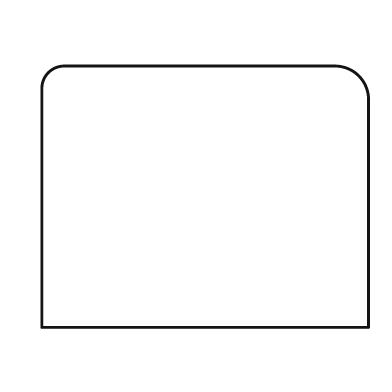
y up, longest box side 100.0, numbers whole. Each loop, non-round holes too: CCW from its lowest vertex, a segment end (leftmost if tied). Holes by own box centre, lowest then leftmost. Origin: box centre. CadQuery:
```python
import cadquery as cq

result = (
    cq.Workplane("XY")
    .moveTo(-50.0, -40.0)
    .lineTo(50.0, -40.0)
    .lineTo(50.0, 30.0)
    .threePointArc((47.0, 37.0), (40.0, 40.0))
    .lineTo(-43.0, 40.0)
    .threePointArc((-48.0, 38.0), (-50.0, 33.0))
    .close()
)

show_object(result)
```